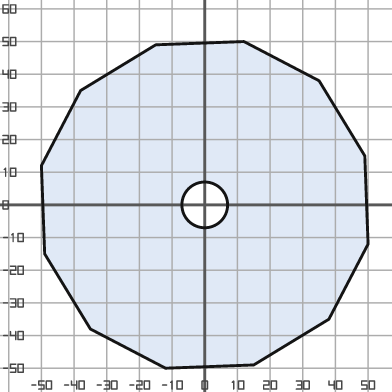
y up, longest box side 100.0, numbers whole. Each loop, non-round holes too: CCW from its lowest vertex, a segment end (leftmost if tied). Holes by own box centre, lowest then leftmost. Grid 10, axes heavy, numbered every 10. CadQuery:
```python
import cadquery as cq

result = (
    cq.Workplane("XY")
    .moveTo(-12.0, -50.0)
    .lineTo(15.0, -49.0)
    .lineTo(38.0, -35.0)
    .lineTo(50.0, -12.0)
    .lineTo(49.0, 15.0)
    .lineTo(35.0, 38.0)
    .lineTo(12.0, 50.0)
    .lineTo(-15.0, 49.0)
    .lineTo(-38.0, 35.0)
    .lineTo(-50.0, 12.0)
    .lineTo(-49.0, -15.0)
    .lineTo(-35.0, -38.0)
    .close()
    .moveTo(0.0, 0.0)
    .circle(7.0)
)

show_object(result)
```